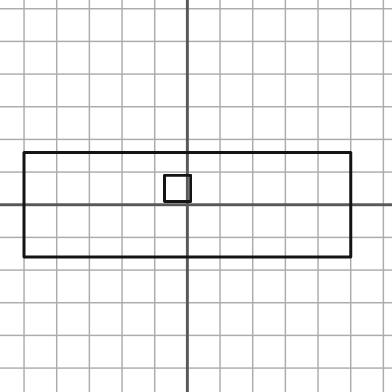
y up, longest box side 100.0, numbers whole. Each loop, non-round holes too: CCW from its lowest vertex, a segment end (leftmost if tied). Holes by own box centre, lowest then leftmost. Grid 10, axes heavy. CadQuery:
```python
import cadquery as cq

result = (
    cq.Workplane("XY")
    .moveTo(-50.0, -16.0)
    .lineTo(50.0, -16.0)
    .lineTo(50.0, 16.0)
    .lineTo(-50.0, 16.0)
    .close()
    .moveTo(-7.0, 1.0)
    .lineTo(1.0, 1.0)
    .lineTo(1.0, 9.0)
    .lineTo(-7.0, 9.0)
    .close()
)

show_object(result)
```